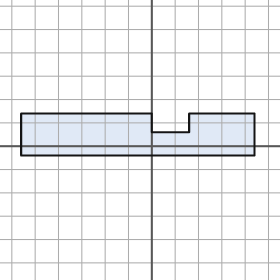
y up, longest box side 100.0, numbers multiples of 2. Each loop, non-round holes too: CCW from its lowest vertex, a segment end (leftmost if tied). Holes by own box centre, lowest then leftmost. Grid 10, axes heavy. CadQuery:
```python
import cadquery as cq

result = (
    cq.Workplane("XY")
    .moveTo(-56.0, -4.0)
    .lineTo(44.0, -4.0)
    .lineTo(44.0, 14.0)
    .lineTo(16.0, 14.0)
    .lineTo(16.0, 6.0)
    .lineTo(0.0, 6.0)
    .lineTo(0.0, 14.0)
    .lineTo(-56.0, 14.0)
    .close()
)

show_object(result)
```